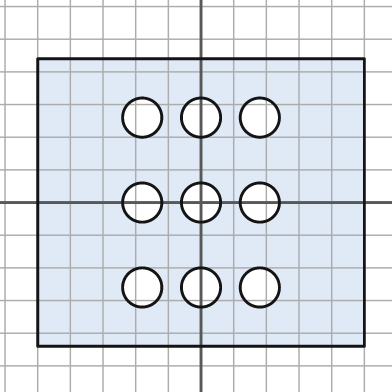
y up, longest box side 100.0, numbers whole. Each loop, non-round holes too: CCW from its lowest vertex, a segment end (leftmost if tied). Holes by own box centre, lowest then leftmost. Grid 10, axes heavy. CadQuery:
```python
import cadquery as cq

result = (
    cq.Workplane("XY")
    .moveTo(-50.0, -44.0)
    .lineTo(50.0, -44.0)
    .lineTo(50.0, 44.0)
    .lineTo(-50.0, 44.0)
    .close()
    .moveTo(-18.0, -26.0)
    .circle(6.0)
    .moveTo(0.0, -26.0)
    .circle(6.0)
    .moveTo(18.0, -26.0)
    .circle(6.0)
    .moveTo(-18.0, 0.0)
    .circle(6.0)
    .moveTo(0.0, 0.0)
    .circle(6.0)
    .moveTo(18.0, 0.0)
    .circle(6.0)
    .moveTo(-18.0, 26.0)
    .circle(6.0)
    .moveTo(0.0, 26.0)
    .circle(6.0)
    .moveTo(18.0, 26.0)
    .circle(6.0)
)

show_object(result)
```